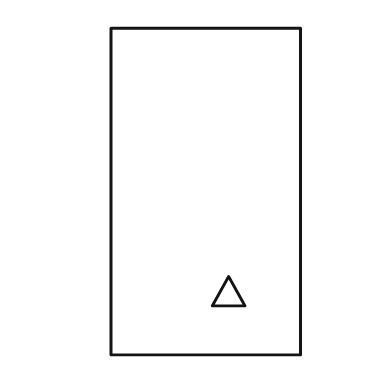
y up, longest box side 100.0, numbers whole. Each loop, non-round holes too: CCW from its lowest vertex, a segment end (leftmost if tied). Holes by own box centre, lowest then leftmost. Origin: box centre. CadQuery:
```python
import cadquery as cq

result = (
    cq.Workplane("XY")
    .moveTo(-29.0, -50.0)
    .lineTo(29.0, -50.0)
    .lineTo(29.0, 50.0)
    .lineTo(-29.0, 50.0)
    .close()
    .moveTo(2.0, -35.0)
    .lineTo(12.0, -35.0)
    .lineTo(7.0, -26.0)
    .close()
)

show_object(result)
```